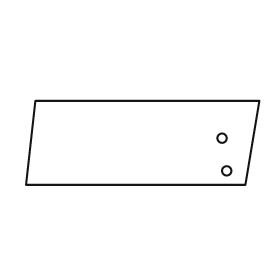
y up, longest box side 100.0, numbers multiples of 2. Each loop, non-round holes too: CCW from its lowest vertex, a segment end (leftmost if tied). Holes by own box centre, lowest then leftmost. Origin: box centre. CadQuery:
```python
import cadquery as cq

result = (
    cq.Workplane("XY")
    .moveTo(-50.0, -18.0)
    .lineTo(44.0, -18.0)
    .lineTo(50.0, 18.0)
    .lineTo(-46.0, 18.0)
    .close()
    .moveTo(36.0, -12.0)
    .circle(2.0)
    .moveTo(34.0, 2.0)
    .circle(2.0)
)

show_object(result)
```